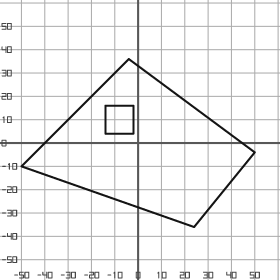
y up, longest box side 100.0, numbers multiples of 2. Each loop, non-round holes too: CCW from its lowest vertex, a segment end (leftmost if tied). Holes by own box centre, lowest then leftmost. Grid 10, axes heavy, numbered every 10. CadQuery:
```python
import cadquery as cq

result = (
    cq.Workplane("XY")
    .moveTo(24.0, -36.0)
    .lineTo(50.0, -4.0)
    .lineTo(-4.0, 36.0)
    .lineTo(-50.0, -10.0)
    .close()
    .moveTo(-14.0, 4.0)
    .lineTo(-2.0, 4.0)
    .lineTo(-2.0, 16.0)
    .lineTo(-14.0, 16.0)
    .close()
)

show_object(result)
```